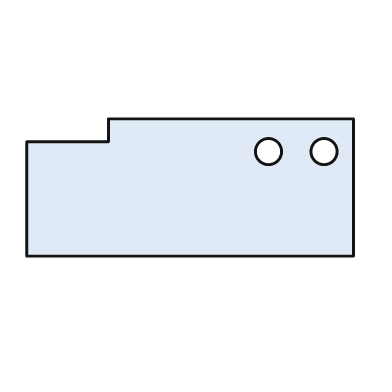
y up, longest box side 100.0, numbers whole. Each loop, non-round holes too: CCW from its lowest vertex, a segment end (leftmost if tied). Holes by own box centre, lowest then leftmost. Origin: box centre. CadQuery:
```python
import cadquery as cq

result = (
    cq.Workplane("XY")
    .moveTo(-50.0, -21.0)
    .lineTo(50.0, -21.0)
    .lineTo(50.0, 21.0)
    .lineTo(-25.0, 21.0)
    .lineTo(-25.0, 14.0)
    .lineTo(-50.0, 14.0)
    .close()
    .moveTo(24.0, 11.0)
    .circle(4.0)
    .moveTo(41.0, 11.0)
    .circle(4.0)
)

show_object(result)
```